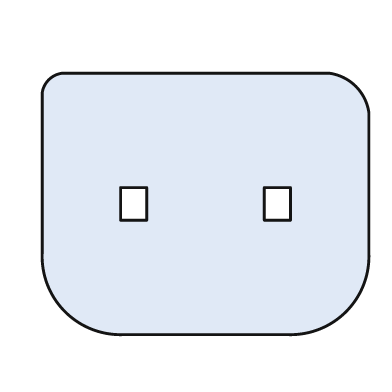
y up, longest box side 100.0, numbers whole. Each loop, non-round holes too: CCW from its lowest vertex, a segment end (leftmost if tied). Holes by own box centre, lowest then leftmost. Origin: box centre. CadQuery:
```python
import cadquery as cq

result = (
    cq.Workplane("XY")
    .moveTo(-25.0, -40.0)
    .lineTo(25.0, -40.0)
    .threePointArc((43.0, -33.0), (50.0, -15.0))
    .lineTo(50.0, 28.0)
    .threePointArc((46.0, 36.0), (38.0, 40.0))
    .lineTo(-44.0, 40.0)
    .threePointArc((-48.0, 38.0), (-50.0, 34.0))
    .lineTo(-50.0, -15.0)
    .threePointArc((-43.0, -33.0), (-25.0, -40.0))
    .close()
    .moveTo(-26.0, -5.0)
    .lineTo(-18.0, -5.0)
    .lineTo(-18.0, 5.0)
    .lineTo(-26.0, 5.0)
    .close()
    .moveTo(18.0, -5.0)
    .lineTo(26.0, -5.0)
    .lineTo(26.0, 5.0)
    .lineTo(18.0, 5.0)
    .close()
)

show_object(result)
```